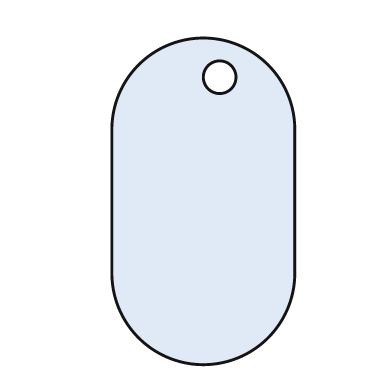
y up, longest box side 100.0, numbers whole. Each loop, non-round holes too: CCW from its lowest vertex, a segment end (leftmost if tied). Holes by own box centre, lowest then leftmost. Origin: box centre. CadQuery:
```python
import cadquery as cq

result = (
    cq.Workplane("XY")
    .moveTo(-28.0, -22.0)
    .threePointArc((0.0, -50.0), (28.0, -22.0))
    .lineTo(28.0, 22.0)
    .threePointArc((0.0, 50.0), (-28.0, 22.0))
    .close()
    .moveTo(5.0, 38.0)
    .circle(5.0)
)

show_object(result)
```